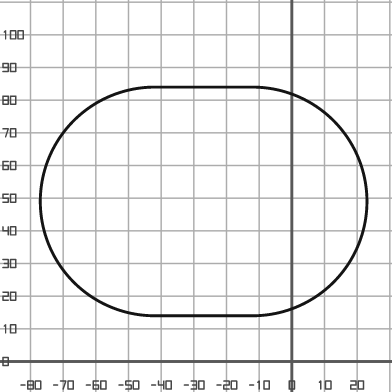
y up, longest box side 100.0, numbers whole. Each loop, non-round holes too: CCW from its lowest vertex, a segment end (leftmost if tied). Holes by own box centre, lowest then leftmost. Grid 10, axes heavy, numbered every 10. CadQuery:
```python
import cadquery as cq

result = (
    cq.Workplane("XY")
    .moveTo(-42.0, 14.0)
    .lineTo(-12.0, 14.0)
    .threePointArc((23.0, 49.0), (-12.0, 84.0))
    .lineTo(-42.0, 84.0)
    .threePointArc((-77.0, 49.0), (-42.0, 14.0))
    .close()
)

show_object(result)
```